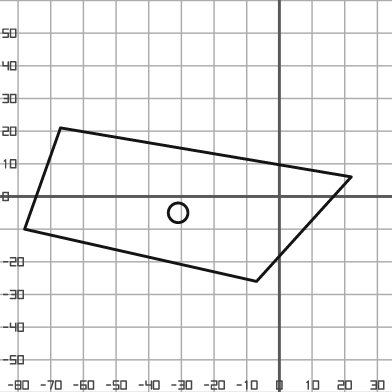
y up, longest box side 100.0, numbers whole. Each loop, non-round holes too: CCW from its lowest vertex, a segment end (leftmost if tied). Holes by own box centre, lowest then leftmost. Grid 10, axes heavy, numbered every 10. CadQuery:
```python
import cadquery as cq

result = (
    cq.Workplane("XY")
    .moveTo(-7.0, -26.0)
    .lineTo(22.0, 6.0)
    .lineTo(-67.0, 21.0)
    .lineTo(-78.0, -10.0)
    .close()
    .moveTo(-31.0, -5.0)
    .circle(3.0)
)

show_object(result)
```